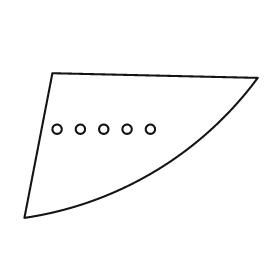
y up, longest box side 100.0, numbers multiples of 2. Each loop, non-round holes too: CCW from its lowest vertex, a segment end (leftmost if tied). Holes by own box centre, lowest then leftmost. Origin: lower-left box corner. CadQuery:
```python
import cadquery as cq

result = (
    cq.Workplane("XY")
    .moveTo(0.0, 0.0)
    .threePointArc((56.0, 20.0), (100.0, 60.0))
    .lineTo(12.0, 62.0)
    .close()
    .moveTo(14.0, 38.0)
    .circle(2.0)
    .moveTo(24.0, 38.0)
    .circle(2.0)
    .moveTo(34.0, 38.0)
    .circle(2.0)
    .moveTo(44.0, 38.0)
    .circle(2.0)
    .moveTo(54.0, 38.0)
    .circle(2.0)
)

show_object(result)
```